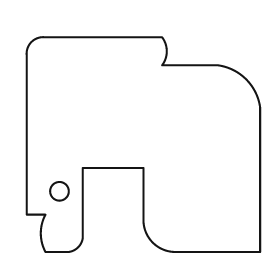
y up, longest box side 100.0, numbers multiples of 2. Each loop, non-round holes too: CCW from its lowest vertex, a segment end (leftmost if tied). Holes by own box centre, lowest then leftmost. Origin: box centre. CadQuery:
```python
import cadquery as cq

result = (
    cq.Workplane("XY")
    .moveTo(-42.0, -46.0)
    .lineTo(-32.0, -46.0)
    .threePointArc((-28.0, -44.0), (-26.0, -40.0))
    .lineTo(-26.0, -10.0)
    .lineTo(0.0, -10.0)
    .lineTo(0.0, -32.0)
    .threePointArc((4.0, -42.0), (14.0, -46.0))
    .lineTo(50.0, -46.0)
    .lineTo(50.0, 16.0)
    .threePointArc((44.0, 28.0), (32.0, 34.0))
    .lineTo(8.0, 34.0)
    .threePointArc((10.0, 40.0), (8.0, 46.0))
    .lineTo(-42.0, 46.0)
    .threePointArc((-48.0, 44.0), (-50.0, 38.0))
    .lineTo(-50.0, -30.0)
    .lineTo(-42.0, -30.0)
    .threePointArc((-44.0, -38.0), (-42.0, -46.0))
    .close()
    .moveTo(-36.0, -20.0)
    .circle(4.0)
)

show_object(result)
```